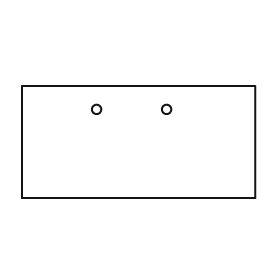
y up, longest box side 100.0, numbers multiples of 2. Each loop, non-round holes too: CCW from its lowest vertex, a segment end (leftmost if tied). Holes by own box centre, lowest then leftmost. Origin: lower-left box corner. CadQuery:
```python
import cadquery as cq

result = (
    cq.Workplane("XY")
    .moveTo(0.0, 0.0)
    .lineTo(100.0, 0.0)
    .lineTo(100.0, 48.0)
    .lineTo(0.0, 48.0)
    .close()
    .moveTo(32.0, 38.0)
    .circle(2.0)
    .moveTo(62.0, 38.0)
    .circle(2.0)
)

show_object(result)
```